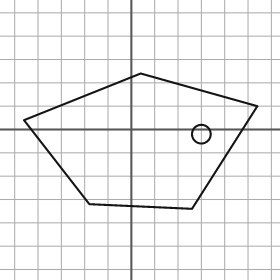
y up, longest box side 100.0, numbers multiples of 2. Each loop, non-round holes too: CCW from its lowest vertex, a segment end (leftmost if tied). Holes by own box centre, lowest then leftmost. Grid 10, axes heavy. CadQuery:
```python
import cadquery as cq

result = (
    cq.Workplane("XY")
    .moveTo(26.0, -34.0)
    .lineTo(54.0, 10.0)
    .lineTo(4.0, 24.0)
    .lineTo(-46.0, 4.0)
    .lineTo(-18.0, -32.0)
    .close()
    .moveTo(30.0, -2.0)
    .circle(4.0)
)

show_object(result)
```